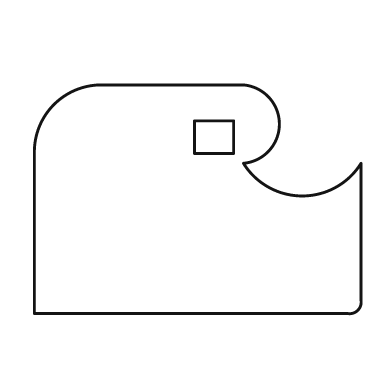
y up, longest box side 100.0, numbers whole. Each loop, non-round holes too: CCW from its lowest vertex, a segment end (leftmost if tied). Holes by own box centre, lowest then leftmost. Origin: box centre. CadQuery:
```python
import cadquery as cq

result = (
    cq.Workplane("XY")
    .moveTo(-50.0, -35.0)
    .lineTo(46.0, -35.0)
    .threePointArc((49.0, -34.0), (50.0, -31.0))
    .lineTo(50.0, 11.0)
    .threePointArc((32.0, 1.0), (14.0, 11.0))
    .threePointArc((25.0, 23.0), (14.0, 35.0))
    .lineTo(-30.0, 35.0)
    .threePointArc((-44.0, 29.0), (-50.0, 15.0))
    .close()
    .moveTo(-1.0, 14.0)
    .lineTo(11.0, 14.0)
    .lineTo(11.0, 24.0)
    .lineTo(-1.0, 24.0)
    .close()
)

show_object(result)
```